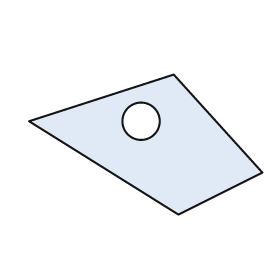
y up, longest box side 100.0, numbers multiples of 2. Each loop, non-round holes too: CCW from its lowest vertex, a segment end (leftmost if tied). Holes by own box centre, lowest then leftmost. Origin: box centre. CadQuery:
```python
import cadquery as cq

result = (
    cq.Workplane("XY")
    .moveTo(14.0, -30.0)
    .lineTo(50.0, -12.0)
    .lineTo(12.0, 30.0)
    .lineTo(-50.0, 10.0)
    .close()
    .moveTo(-2.0, 10.0)
    .circle(8.0)
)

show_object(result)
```